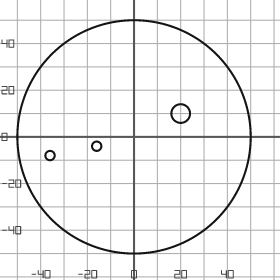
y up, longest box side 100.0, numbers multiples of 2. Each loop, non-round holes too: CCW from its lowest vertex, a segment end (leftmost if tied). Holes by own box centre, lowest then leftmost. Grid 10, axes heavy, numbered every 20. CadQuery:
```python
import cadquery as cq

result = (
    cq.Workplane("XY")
    .moveTo(0.0, 0.0)
    .circle(50.0)
    .moveTo(-36.0, -8.0)
    .circle(2.0)
    .moveTo(-16.0, -4.0)
    .circle(2.0)
    .moveTo(20.0, 10.0)
    .circle(4.0)
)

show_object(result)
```